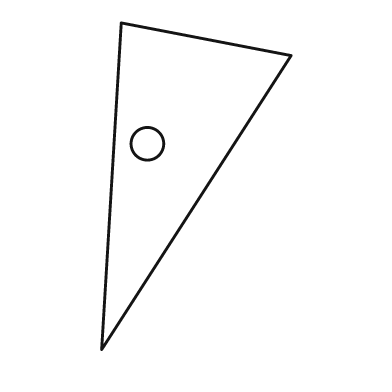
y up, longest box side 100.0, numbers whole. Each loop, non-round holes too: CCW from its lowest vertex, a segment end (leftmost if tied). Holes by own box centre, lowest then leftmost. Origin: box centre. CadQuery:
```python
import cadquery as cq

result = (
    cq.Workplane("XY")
    .moveTo(-29.0, -50.0)
    .lineTo(29.0, 40.0)
    .lineTo(-23.0, 50.0)
    .close()
    .moveTo(-15.0, 13.0)
    .circle(5.0)
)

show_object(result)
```